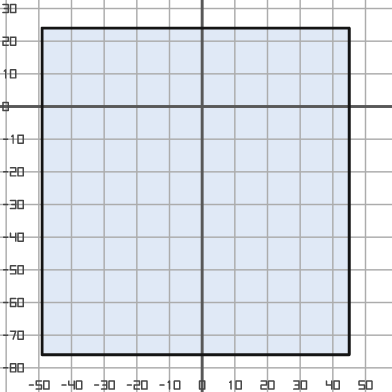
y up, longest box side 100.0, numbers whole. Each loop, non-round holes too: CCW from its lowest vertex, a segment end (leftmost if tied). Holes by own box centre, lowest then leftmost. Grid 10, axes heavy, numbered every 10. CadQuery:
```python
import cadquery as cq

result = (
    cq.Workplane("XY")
    .moveTo(-49.0, -76.0)
    .lineTo(45.0, -76.0)
    .lineTo(45.0, 24.0)
    .lineTo(-49.0, 24.0)
    .close()
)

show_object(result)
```